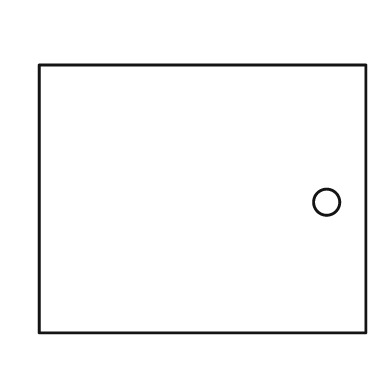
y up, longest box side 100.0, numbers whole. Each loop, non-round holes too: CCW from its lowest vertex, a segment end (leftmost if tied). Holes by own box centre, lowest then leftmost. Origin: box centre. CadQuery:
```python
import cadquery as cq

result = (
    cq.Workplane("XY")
    .moveTo(-50.0, -41.0)
    .lineTo(50.0, -41.0)
    .lineTo(50.0, 41.0)
    .lineTo(-50.0, 41.0)
    .close()
    .moveTo(38.0, -1.0)
    .circle(4.0)
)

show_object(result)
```